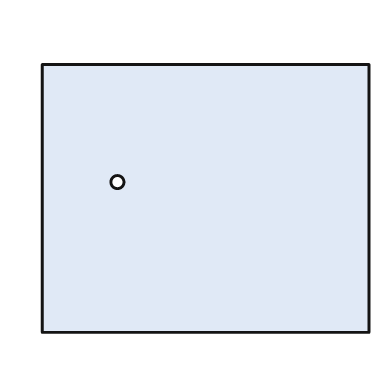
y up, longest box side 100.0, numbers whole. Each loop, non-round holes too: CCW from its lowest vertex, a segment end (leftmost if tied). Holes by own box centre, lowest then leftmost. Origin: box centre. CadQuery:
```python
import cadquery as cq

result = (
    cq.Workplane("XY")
    .moveTo(-50.0, -41.0)
    .lineTo(50.0, -41.0)
    .lineTo(50.0, 41.0)
    .lineTo(-50.0, 41.0)
    .close()
    .moveTo(-27.0, 5.0)
    .circle(2.0)
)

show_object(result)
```